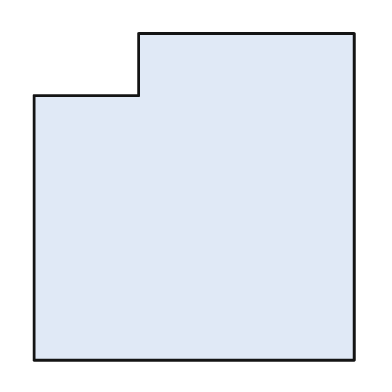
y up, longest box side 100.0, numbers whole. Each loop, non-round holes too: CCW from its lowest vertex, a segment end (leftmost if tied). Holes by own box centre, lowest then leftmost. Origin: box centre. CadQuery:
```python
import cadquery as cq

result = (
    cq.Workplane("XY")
    .moveTo(-49.0, -50.0)
    .lineTo(49.0, -50.0)
    .lineTo(49.0, 50.0)
    .lineTo(-17.0, 50.0)
    .lineTo(-17.0, 31.0)
    .lineTo(-49.0, 31.0)
    .close()
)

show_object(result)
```